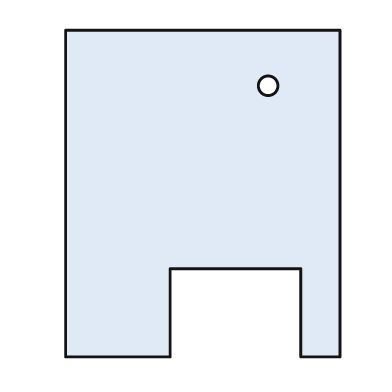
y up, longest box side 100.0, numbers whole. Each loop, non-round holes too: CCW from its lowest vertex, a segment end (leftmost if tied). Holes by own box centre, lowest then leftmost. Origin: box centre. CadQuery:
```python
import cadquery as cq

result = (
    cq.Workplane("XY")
    .moveTo(-42.0, -50.0)
    .lineTo(-10.0, -50.0)
    .lineTo(-10.0, -23.0)
    .lineTo(30.0, -23.0)
    .lineTo(30.0, -50.0)
    .lineTo(42.0, -50.0)
    .lineTo(42.0, 50.0)
    .lineTo(-42.0, 50.0)
    .close()
    .moveTo(20.0, 33.0)
    .circle(3.0)
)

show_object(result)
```